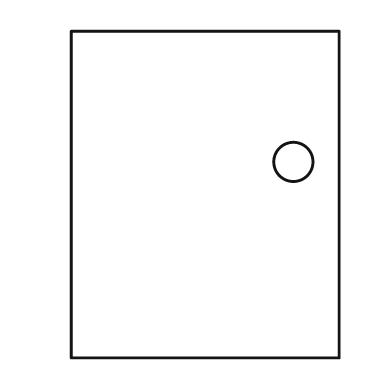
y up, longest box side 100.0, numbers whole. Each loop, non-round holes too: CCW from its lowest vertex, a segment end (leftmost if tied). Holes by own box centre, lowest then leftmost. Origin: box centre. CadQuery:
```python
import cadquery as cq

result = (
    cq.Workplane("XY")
    .moveTo(-41.0, -50.0)
    .lineTo(41.0, -50.0)
    .lineTo(41.0, 50.0)
    .lineTo(-41.0, 50.0)
    .close()
    .moveTo(27.0, 10.0)
    .circle(6.0)
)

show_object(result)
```